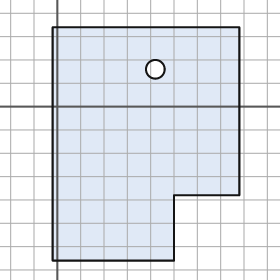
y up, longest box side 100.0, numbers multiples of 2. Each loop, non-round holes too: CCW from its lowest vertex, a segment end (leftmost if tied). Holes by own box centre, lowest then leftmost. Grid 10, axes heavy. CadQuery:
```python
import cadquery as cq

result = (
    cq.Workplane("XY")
    .moveTo(-2.0, -66.0)
    .lineTo(50.0, -66.0)
    .lineTo(50.0, -38.0)
    .lineTo(78.0, -38.0)
    .lineTo(78.0, 34.0)
    .lineTo(-2.0, 34.0)
    .close()
    .moveTo(42.0, 16.0)
    .circle(4.0)
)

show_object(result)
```